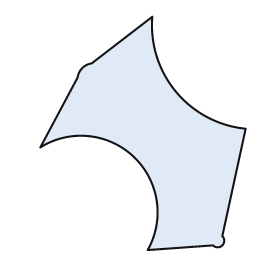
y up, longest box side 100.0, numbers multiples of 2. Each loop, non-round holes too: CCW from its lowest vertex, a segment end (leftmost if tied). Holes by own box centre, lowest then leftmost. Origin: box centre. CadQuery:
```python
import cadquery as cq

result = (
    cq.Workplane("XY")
    .moveTo(2.0, -50.0)
    .lineTo(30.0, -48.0)
    .threePointArc((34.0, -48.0), (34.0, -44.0))
    .lineTo(44.0, 2.0)
    .threePointArc((14.0, 18.0), (4.0, 50.0))
    .lineTo(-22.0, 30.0)
    .threePointArc((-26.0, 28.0), (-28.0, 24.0))
    .lineTo(-44.0, -6.0)
    .threePointArc((-4.0, -10.0), (2.0, -50.0))
    .close()
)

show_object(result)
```